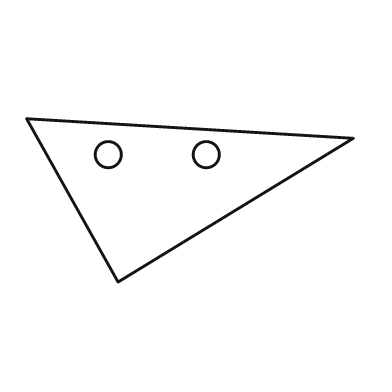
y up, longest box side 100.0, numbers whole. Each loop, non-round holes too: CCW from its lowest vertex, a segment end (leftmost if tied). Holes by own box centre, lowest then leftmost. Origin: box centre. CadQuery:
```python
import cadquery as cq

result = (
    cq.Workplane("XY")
    .moveTo(-22.0, -25.0)
    .lineTo(50.0, 19.0)
    .lineTo(-50.0, 25.0)
    .close()
    .moveTo(-25.0, 14.0)
    .circle(4.0)
    .moveTo(5.0, 14.0)
    .circle(4.0)
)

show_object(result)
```